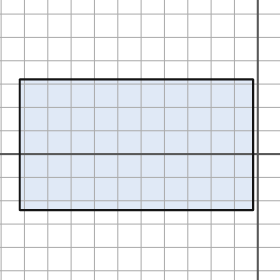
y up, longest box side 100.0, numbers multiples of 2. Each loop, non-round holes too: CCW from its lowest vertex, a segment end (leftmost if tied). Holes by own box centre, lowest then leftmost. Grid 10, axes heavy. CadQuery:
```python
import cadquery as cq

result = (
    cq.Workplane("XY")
    .moveTo(-102.0, -24.0)
    .lineTo(-2.0, -24.0)
    .lineTo(-2.0, 32.0)
    .lineTo(-102.0, 32.0)
    .close()
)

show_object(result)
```